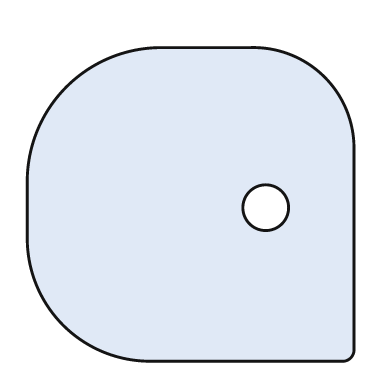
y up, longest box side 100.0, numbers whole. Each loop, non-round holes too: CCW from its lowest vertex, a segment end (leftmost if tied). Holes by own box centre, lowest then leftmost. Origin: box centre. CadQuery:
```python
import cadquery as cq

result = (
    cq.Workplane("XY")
    .moveTo(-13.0, -48.0)
    .lineTo(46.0, -48.0)
    .threePointArc((49.0, -47.0), (50.0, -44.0))
    .lineTo(50.0, 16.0)
    .threePointArc((41.0, 39.0), (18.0, 48.0))
    .lineTo(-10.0, 48.0)
    .threePointArc((-38.0, 36.0), (-50.0, 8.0))
    .lineTo(-50.0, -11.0)
    .threePointArc((-39.0, -37.0), (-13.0, -48.0))
    .close()
    .moveTo(23.0, -1.0)
    .circle(7.0)
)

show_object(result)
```